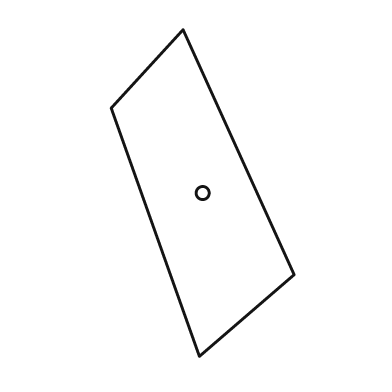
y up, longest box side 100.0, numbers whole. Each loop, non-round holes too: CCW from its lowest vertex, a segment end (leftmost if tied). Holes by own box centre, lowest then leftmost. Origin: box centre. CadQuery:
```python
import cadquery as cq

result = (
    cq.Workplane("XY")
    .moveTo(-1.0, -50.0)
    .lineTo(28.0, -25.0)
    .lineTo(-6.0, 50.0)
    .lineTo(-28.0, 26.0)
    .close()
    .moveTo(0.0, 0.0)
    .circle(2.0)
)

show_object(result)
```